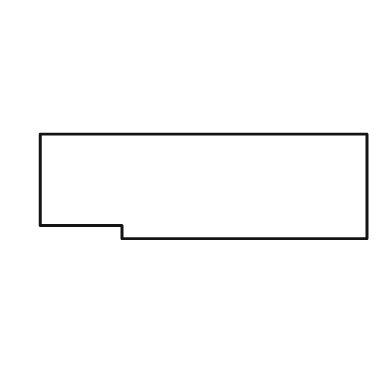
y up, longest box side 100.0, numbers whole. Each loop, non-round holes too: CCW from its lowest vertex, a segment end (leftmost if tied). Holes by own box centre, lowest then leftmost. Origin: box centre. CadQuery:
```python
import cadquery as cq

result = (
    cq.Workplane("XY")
    .moveTo(-25.0, -16.0)
    .lineTo(50.0, -16.0)
    .lineTo(50.0, 16.0)
    .lineTo(-50.0, 16.0)
    .lineTo(-50.0, -12.0)
    .lineTo(-25.0, -12.0)
    .close()
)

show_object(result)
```